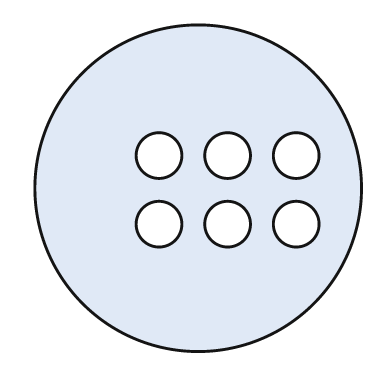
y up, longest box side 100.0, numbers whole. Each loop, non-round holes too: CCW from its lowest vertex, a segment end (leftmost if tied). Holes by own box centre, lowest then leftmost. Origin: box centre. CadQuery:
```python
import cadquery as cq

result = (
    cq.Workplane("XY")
    .moveTo(0.0, 0.0)
    .circle(50.0)
    .moveTo(-12.0, -11.0)
    .circle(7.0)
    .moveTo(9.0, -11.0)
    .circle(7.0)
    .moveTo(30.0, -11.0)
    .circle(7.0)
    .moveTo(-12.0, 10.0)
    .circle(7.0)
    .moveTo(9.0, 10.0)
    .circle(7.0)
    .moveTo(30.0, 10.0)
    .circle(7.0)
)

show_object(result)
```